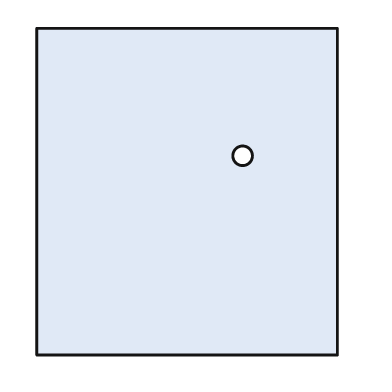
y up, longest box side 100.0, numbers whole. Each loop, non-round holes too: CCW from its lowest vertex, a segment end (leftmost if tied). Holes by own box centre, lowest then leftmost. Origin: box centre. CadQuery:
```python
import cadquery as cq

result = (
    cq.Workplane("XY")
    .moveTo(-46.0, -50.0)
    .lineTo(46.0, -50.0)
    .lineTo(46.0, 50.0)
    .lineTo(-46.0, 50.0)
    .close()
    .moveTo(17.0, 11.0)
    .circle(3.0)
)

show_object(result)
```